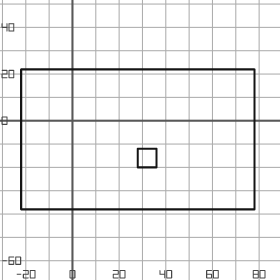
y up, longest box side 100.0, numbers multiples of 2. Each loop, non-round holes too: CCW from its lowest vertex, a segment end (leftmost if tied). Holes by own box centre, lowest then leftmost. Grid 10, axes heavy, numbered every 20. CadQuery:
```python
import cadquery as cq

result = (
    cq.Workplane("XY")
    .moveTo(-22.0, -38.0)
    .lineTo(78.0, -38.0)
    .lineTo(78.0, 22.0)
    .lineTo(-22.0, 22.0)
    .close()
    .moveTo(28.0, -20.0)
    .lineTo(36.0, -20.0)
    .lineTo(36.0, -12.0)
    .lineTo(28.0, -12.0)
    .close()
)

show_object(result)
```